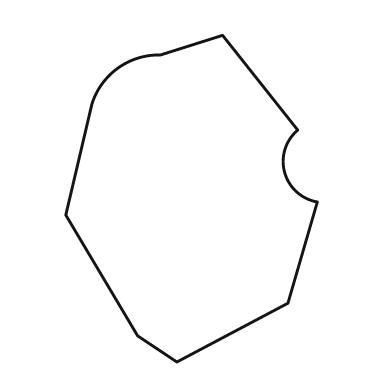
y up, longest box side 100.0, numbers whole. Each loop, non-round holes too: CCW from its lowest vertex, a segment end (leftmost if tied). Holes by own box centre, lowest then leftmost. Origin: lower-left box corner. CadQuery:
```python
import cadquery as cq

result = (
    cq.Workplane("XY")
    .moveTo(34.0, 0.0)
    .lineTo(68.0, 18.0)
    .lineTo(77.0, 49.0)
    .threePointArc((67.0, 58.0), (71.0, 71.0))
    .lineTo(48.0, 100.0)
    .lineTo(29.0, 94.0)
    .threePointArc((16.0, 90.0), (8.0, 79.0))
    .lineTo(0.0, 45.0)
    .lineTo(22.0, 8.0)
    .close()
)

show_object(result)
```